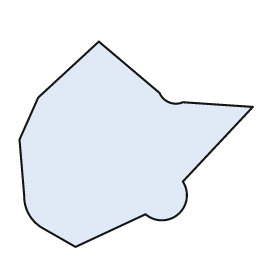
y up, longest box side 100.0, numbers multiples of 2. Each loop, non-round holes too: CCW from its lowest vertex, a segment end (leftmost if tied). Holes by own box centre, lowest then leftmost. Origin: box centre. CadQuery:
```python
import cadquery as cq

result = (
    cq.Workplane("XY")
    .moveTo(-26.0, -44.0)
    .lineTo(4.0, -30.0)
    .threePointArc((18.0, -30.0), (20.0, -16.0))
    .lineTo(50.0, 16.0)
    .lineTo(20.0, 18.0)
    .threePointArc((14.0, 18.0), (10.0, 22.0))
    .lineTo(-16.0, 44.0)
    .lineTo(-42.0, 20.0)
    .lineTo(-50.0, 2.0)
    .lineTo(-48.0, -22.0)
    .threePointArc((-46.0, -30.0), (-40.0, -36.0))
    .close()
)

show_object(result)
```